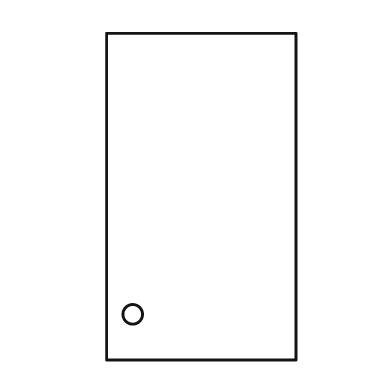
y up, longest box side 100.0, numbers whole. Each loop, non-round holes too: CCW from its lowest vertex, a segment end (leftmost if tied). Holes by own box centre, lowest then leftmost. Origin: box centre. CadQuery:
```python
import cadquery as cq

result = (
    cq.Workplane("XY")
    .moveTo(-29.0, -50.0)
    .lineTo(29.0, -50.0)
    .lineTo(29.0, 50.0)
    .lineTo(-29.0, 50.0)
    .close()
    .moveTo(-21.0, -36.0)
    .circle(3.0)
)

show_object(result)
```